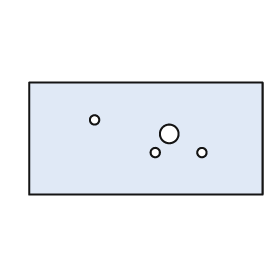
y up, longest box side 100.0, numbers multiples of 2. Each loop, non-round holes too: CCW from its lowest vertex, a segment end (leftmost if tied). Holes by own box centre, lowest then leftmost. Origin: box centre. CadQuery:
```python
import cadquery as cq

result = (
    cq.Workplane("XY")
    .moveTo(-50.0, -24.0)
    .lineTo(50.0, -24.0)
    .lineTo(50.0, 24.0)
    .lineTo(-50.0, 24.0)
    .close()
    .moveTo(4.0, -6.0)
    .circle(2.0)
    .moveTo(24.0, -6.0)
    .circle(2.0)
    .moveTo(10.0, 2.0)
    .circle(4.0)
    .moveTo(-22.0, 8.0)
    .circle(2.0)
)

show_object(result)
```